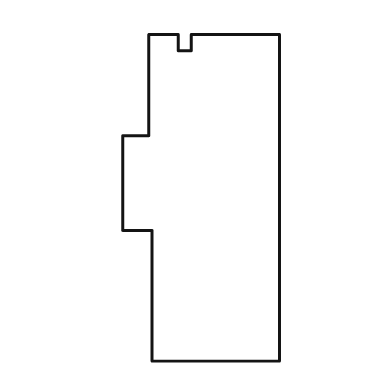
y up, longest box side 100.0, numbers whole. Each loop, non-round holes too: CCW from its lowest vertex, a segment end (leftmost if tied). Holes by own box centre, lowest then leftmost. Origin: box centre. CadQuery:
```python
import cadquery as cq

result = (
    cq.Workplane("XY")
    .moveTo(-15.0, -50.0)
    .lineTo(24.0, -50.0)
    .lineTo(24.0, 50.0)
    .lineTo(-3.0, 50.0)
    .lineTo(-3.0, 45.0)
    .lineTo(-7.0, 45.0)
    .lineTo(-7.0, 50.0)
    .lineTo(-16.0, 50.0)
    .lineTo(-16.0, 19.0)
    .lineTo(-24.0, 19.0)
    .lineTo(-24.0, -10.0)
    .lineTo(-15.0, -10.0)
    .close()
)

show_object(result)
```